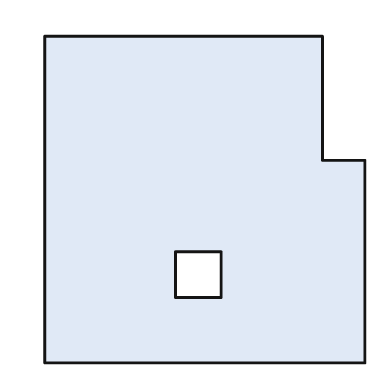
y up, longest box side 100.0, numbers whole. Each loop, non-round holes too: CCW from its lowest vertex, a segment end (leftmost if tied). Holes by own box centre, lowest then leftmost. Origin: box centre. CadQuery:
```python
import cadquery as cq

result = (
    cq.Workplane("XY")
    .moveTo(-49.0, -50.0)
    .lineTo(49.0, -50.0)
    .lineTo(49.0, 12.0)
    .lineTo(36.0, 12.0)
    .lineTo(36.0, 50.0)
    .lineTo(-49.0, 50.0)
    .close()
    .moveTo(-9.0, -30.0)
    .lineTo(5.0, -30.0)
    .lineTo(5.0, -16.0)
    .lineTo(-9.0, -16.0)
    .close()
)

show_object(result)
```